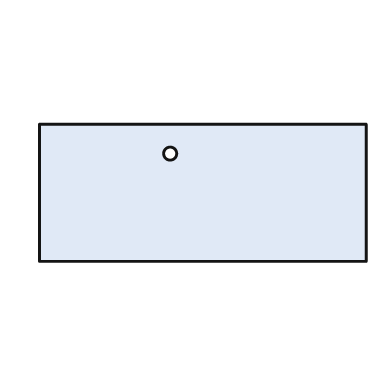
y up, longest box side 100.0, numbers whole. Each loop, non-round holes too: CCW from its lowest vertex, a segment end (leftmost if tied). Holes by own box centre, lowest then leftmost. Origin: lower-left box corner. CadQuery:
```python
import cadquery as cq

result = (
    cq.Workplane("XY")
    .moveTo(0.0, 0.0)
    .lineTo(100.0, 0.0)
    .lineTo(100.0, 42.0)
    .lineTo(0.0, 42.0)
    .close()
    .moveTo(40.0, 33.0)
    .circle(2.0)
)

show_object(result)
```